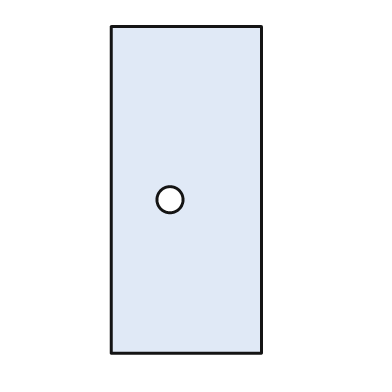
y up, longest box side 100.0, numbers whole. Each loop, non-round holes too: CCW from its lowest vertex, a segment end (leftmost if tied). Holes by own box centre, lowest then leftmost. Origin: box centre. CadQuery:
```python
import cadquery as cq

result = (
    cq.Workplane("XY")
    .moveTo(-23.0, -50.0)
    .lineTo(23.0, -50.0)
    .lineTo(23.0, 50.0)
    .lineTo(-23.0, 50.0)
    .close()
    .moveTo(-5.0, -3.0)
    .circle(4.0)
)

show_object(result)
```